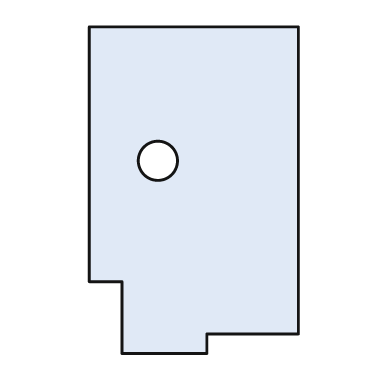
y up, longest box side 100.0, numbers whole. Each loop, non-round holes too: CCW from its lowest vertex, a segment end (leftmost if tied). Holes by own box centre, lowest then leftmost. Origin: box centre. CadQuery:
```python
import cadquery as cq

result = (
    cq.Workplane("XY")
    .moveTo(-22.0, -50.0)
    .lineTo(4.0, -50.0)
    .lineTo(4.0, -44.0)
    .lineTo(32.0, -44.0)
    .lineTo(32.0, 50.0)
    .lineTo(-32.0, 50.0)
    .lineTo(-32.0, -28.0)
    .lineTo(-22.0, -28.0)
    .close()
    .moveTo(-11.0, 9.0)
    .circle(6.0)
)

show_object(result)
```